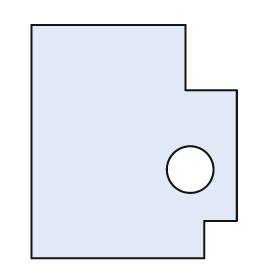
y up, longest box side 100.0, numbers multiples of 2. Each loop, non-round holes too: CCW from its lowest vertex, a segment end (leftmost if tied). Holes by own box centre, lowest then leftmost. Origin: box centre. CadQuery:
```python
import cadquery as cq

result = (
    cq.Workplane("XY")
    .moveTo(-44.0, -50.0)
    .lineTo(30.0, -50.0)
    .lineTo(30.0, -34.0)
    .lineTo(44.0, -34.0)
    .lineTo(44.0, 22.0)
    .lineTo(22.0, 22.0)
    .lineTo(22.0, 50.0)
    .lineTo(-44.0, 50.0)
    .close()
    .moveTo(24.0, -12.0)
    .circle(10.0)
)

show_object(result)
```